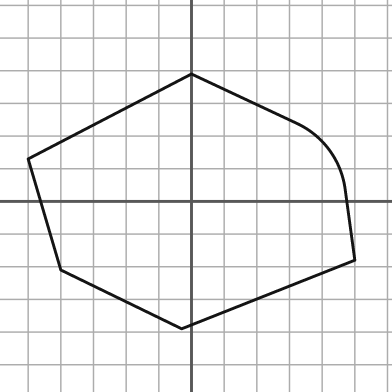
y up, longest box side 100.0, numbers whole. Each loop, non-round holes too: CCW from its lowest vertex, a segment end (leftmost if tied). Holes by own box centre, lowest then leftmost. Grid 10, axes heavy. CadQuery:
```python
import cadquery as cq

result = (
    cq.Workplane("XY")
    .moveTo(-3.0, -39.0)
    .lineTo(50.0, -18.0)
    .lineTo(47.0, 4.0)
    .threePointArc((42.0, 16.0), (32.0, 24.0))
    .lineTo(0.0, 39.0)
    .lineTo(-50.0, 13.0)
    .lineTo(-40.0, -21.0)
    .close()
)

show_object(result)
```